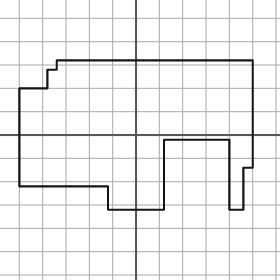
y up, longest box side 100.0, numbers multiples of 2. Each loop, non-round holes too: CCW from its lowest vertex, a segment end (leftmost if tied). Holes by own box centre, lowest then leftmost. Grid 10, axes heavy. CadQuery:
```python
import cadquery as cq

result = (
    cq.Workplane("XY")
    .moveTo(-12.0, -32.0)
    .lineTo(12.0, -32.0)
    .lineTo(12.0, -2.0)
    .lineTo(40.0, -2.0)
    .lineTo(40.0, -32.0)
    .lineTo(46.0, -32.0)
    .lineTo(46.0, -14.0)
    .lineTo(50.0, -14.0)
    .lineTo(50.0, 32.0)
    .lineTo(-34.0, 32.0)
    .lineTo(-34.0, 28.0)
    .lineTo(-38.0, 28.0)
    .lineTo(-38.0, 20.0)
    .lineTo(-50.0, 20.0)
    .lineTo(-50.0, -22.0)
    .lineTo(-12.0, -22.0)
    .close()
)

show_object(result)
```